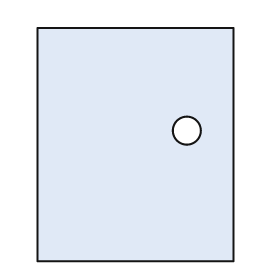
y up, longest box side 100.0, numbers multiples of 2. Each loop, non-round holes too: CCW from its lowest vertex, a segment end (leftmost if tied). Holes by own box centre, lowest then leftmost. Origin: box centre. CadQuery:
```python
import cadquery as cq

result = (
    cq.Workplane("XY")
    .moveTo(-42.0, -50.0)
    .lineTo(42.0, -50.0)
    .lineTo(42.0, 50.0)
    .lineTo(-42.0, 50.0)
    .close()
    .moveTo(22.0, 6.0)
    .circle(6.0)
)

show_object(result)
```